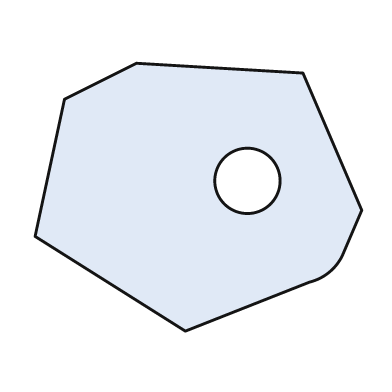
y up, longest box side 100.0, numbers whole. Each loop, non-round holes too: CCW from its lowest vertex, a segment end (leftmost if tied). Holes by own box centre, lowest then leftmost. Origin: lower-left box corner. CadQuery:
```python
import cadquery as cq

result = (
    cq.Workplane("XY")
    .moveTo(46.0, 0.0)
    .lineTo(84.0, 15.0)
    .threePointArc((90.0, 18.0), (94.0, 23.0))
    .lineTo(100.0, 37.0)
    .lineTo(82.0, 79.0)
    .lineTo(31.0, 82.0)
    .lineTo(9.0, 71.0)
    .lineTo(0.0, 29.0)
    .close()
    .moveTo(65.0, 46.0)
    .circle(10.0)
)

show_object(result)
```